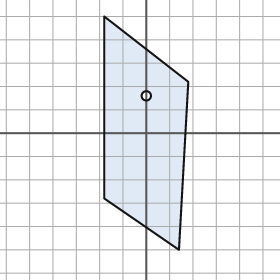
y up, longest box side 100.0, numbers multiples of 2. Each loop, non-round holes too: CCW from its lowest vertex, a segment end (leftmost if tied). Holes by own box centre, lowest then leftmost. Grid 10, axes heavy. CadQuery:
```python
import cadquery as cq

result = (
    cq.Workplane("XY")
    .moveTo(14.0, -50.0)
    .lineTo(18.0, 22.0)
    .lineTo(-18.0, 50.0)
    .lineTo(-18.0, -28.0)
    .close()
    .moveTo(0.0, 16.0)
    .circle(2.0)
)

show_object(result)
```